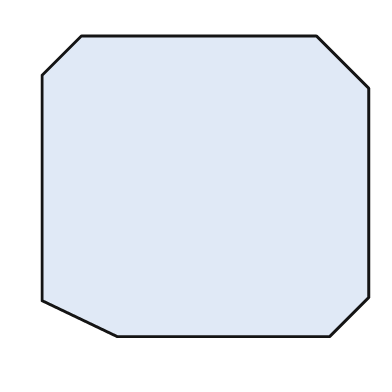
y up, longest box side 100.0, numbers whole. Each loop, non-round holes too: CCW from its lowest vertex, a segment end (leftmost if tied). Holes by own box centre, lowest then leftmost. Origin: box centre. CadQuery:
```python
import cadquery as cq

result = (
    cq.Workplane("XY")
    .moveTo(-27.0, -46.0)
    .lineTo(38.0, -46.0)
    .lineTo(50.0, -34.0)
    .lineTo(50.0, 30.0)
    .lineTo(34.0, 46.0)
    .lineTo(-38.0, 46.0)
    .lineTo(-50.0, 34.0)
    .lineTo(-50.0, -35.0)
    .close()
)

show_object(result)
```